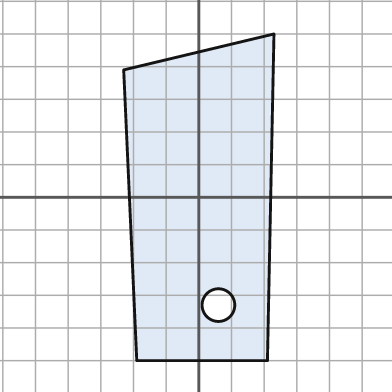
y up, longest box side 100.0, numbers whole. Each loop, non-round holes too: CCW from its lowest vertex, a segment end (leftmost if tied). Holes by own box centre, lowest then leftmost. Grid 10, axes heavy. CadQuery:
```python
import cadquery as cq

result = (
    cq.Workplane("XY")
    .moveTo(-19.0, -50.0)
    .lineTo(21.0, -50.0)
    .lineTo(23.0, 50.0)
    .lineTo(-23.0, 39.0)
    .close()
    .moveTo(6.0, -33.0)
    .circle(5.0)
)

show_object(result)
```